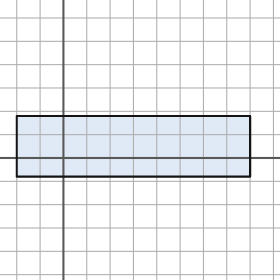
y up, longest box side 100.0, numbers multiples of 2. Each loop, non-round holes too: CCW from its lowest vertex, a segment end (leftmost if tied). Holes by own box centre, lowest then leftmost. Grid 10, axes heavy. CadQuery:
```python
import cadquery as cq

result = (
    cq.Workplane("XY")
    .moveTo(-20.0, -8.0)
    .lineTo(80.0, -8.0)
    .lineTo(80.0, 18.0)
    .lineTo(-20.0, 18.0)
    .close()
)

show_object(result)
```